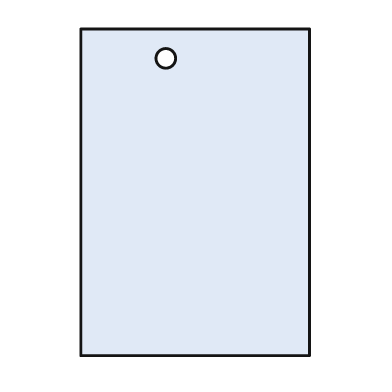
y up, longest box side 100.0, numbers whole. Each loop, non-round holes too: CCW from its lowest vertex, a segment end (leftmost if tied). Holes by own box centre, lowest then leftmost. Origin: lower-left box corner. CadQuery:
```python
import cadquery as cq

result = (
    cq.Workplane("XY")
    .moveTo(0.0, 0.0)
    .lineTo(70.0, 0.0)
    .lineTo(70.0, 100.0)
    .lineTo(0.0, 100.0)
    .close()
    .moveTo(26.0, 91.0)
    .circle(3.0)
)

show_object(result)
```